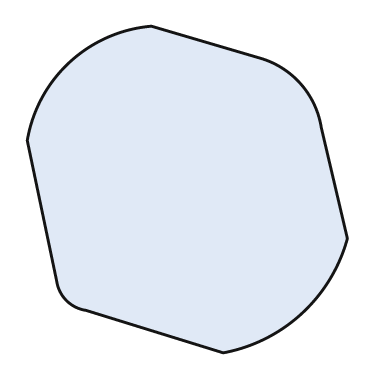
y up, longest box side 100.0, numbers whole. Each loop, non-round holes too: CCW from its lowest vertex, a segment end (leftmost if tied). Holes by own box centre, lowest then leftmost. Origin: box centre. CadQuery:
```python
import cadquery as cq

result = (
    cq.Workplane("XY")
    .moveTo(11.0, -50.0)
    .threePointArc((35.0, -38.0), (49.0, -15.0))
    .lineTo(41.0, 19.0)
    .threePointArc((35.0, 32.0), (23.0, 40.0))
    .lineTo(-11.0, 50.0)
    .threePointArc((-36.0, 39.0), (-49.0, 15.0))
    .lineTo(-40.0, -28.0)
    .threePointArc((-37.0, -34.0), (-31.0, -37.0))
    .close()
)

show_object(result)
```